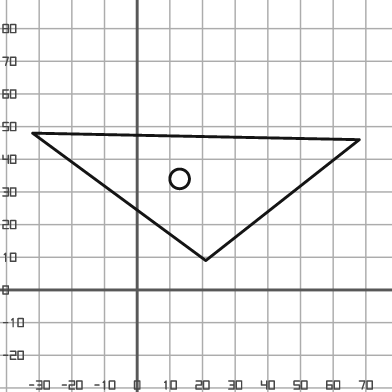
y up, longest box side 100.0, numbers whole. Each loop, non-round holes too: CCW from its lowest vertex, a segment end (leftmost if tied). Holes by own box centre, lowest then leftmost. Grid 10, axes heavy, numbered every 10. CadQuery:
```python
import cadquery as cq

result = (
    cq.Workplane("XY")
    .moveTo(21.0, 9.0)
    .lineTo(68.0, 46.0)
    .lineTo(-32.0, 48.0)
    .close()
    .moveTo(13.0, 34.0)
    .circle(3.0)
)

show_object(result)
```